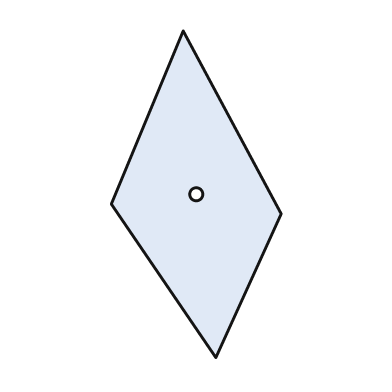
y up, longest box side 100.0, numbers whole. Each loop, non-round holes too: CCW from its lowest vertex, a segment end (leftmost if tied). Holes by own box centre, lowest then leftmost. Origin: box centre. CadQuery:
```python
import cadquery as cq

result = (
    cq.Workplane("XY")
    .moveTo(6.0, -50.0)
    .lineTo(26.0, -6.0)
    .lineTo(-4.0, 50.0)
    .lineTo(-26.0, -3.0)
    .close()
    .moveTo(0.0, 0.0)
    .circle(2.0)
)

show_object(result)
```